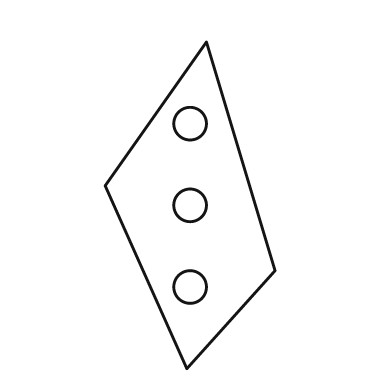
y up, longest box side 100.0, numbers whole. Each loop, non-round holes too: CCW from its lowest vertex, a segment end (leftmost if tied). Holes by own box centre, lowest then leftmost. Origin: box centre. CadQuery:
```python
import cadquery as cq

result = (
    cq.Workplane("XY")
    .moveTo(-1.0, -50.0)
    .lineTo(26.0, -20.0)
    .lineTo(5.0, 50.0)
    .lineTo(-26.0, 6.0)
    .close()
    .moveTo(0.0, -25.0)
    .circle(5.0)
    .moveTo(0.0, 0.0)
    .circle(5.0)
    .moveTo(0.0, 25.0)
    .circle(5.0)
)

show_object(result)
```